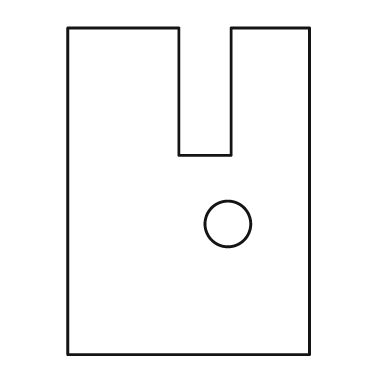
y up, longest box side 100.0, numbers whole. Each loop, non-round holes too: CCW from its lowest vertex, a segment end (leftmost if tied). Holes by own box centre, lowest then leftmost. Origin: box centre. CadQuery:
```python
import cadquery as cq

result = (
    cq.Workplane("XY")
    .moveTo(-37.0, -50.0)
    .lineTo(37.0, -50.0)
    .lineTo(37.0, 50.0)
    .lineTo(13.0, 50.0)
    .lineTo(13.0, 11.0)
    .lineTo(-3.0, 11.0)
    .lineTo(-3.0, 50.0)
    .lineTo(-37.0, 50.0)
    .close()
    .moveTo(12.0, -10.0)
    .circle(7.0)
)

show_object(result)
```